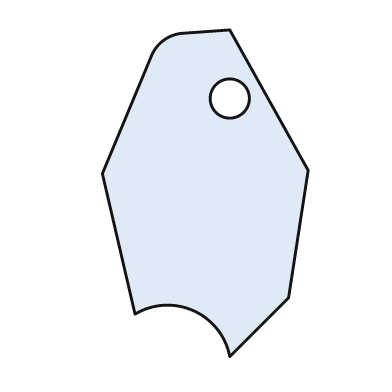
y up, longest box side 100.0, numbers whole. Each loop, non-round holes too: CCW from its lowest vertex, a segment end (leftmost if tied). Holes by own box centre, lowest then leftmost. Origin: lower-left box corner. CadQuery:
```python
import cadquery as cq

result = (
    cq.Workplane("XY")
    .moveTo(39.0, 0.0)
    .lineTo(57.0, 18.0)
    .lineTo(63.0, 57.0)
    .lineTo(39.0, 100.0)
    .lineTo(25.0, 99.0)
    .threePointArc((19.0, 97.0), (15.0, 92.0))
    .lineTo(0.0, 56.0)
    .lineTo(10.0, 13.0)
    .threePointArc((28.0, 14.0), (39.0, 0.0))
    .close()
    .moveTo(39.0, 79.0)
    .circle(6.0)
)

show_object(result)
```